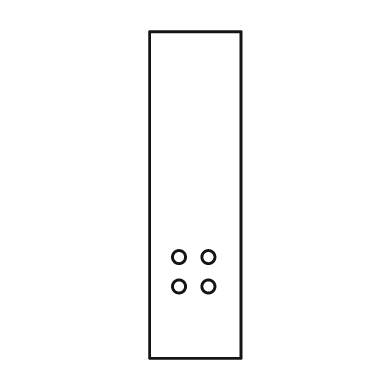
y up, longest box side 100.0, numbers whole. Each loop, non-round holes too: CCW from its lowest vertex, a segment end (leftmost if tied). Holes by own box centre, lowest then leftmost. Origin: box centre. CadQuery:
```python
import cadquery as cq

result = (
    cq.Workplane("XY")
    .moveTo(-14.0, -50.0)
    .lineTo(14.0, -50.0)
    .lineTo(14.0, 50.0)
    .lineTo(-14.0, 50.0)
    .close()
    .moveTo(-5.0, -28.0)
    .circle(2.0)
    .moveTo(4.0, -28.0)
    .circle(2.0)
    .moveTo(-5.0, -19.0)
    .circle(2.0)
    .moveTo(4.0, -19.0)
    .circle(2.0)
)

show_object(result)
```